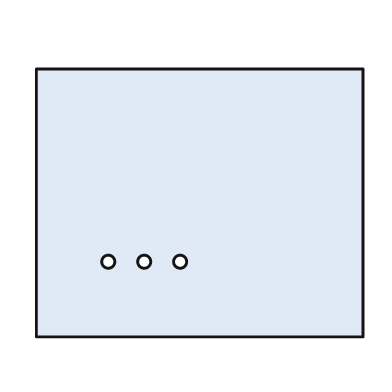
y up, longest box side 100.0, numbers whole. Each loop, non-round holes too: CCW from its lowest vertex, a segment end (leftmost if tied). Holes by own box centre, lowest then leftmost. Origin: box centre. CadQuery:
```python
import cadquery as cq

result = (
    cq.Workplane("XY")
    .moveTo(-50.0, -41.0)
    .lineTo(50.0, -41.0)
    .lineTo(50.0, 41.0)
    .lineTo(-50.0, 41.0)
    .close()
    .moveTo(-28.0, -18.0)
    .circle(2.0)
    .moveTo(-17.0, -18.0)
    .circle(2.0)
    .moveTo(-6.0, -18.0)
    .circle(2.0)
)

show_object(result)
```